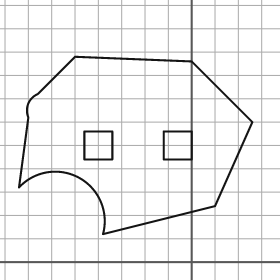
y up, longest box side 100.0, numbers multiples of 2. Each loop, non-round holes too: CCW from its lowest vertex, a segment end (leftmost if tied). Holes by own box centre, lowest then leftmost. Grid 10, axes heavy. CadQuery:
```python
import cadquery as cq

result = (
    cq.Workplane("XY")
    .moveTo(-38.0, 12.0)
    .lineTo(10.0, 24.0)
    .lineTo(26.0, 60.0)
    .lineTo(0.0, 86.0)
    .lineTo(-50.0, 88.0)
    .lineTo(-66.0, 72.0)
    .threePointArc((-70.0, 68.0), (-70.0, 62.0))
    .lineTo(-74.0, 32.0)
    .threePointArc((-48.0, 36.0), (-38.0, 12.0))
    .close()
    .moveTo(-46.0, 44.0)
    .lineTo(-34.0, 44.0)
    .lineTo(-34.0, 56.0)
    .lineTo(-46.0, 56.0)
    .close()
    .moveTo(-12.0, 44.0)
    .lineTo(0.0, 44.0)
    .lineTo(0.0, 56.0)
    .lineTo(-12.0, 56.0)
    .close()
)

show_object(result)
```